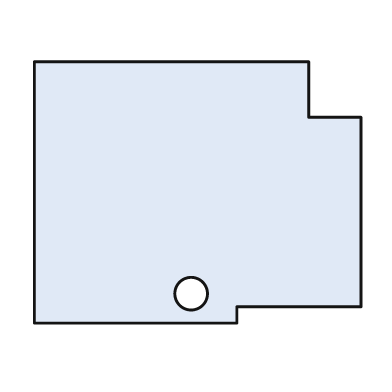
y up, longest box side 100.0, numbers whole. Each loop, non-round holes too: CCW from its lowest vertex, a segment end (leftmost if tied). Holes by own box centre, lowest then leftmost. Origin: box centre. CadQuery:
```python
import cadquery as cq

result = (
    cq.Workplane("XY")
    .moveTo(-50.0, -40.0)
    .lineTo(12.0, -40.0)
    .lineTo(12.0, -35.0)
    .lineTo(50.0, -35.0)
    .lineTo(50.0, 23.0)
    .lineTo(34.0, 23.0)
    .lineTo(34.0, 40.0)
    .lineTo(-50.0, 40.0)
    .close()
    .moveTo(-2.0, -31.0)
    .circle(5.0)
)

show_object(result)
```